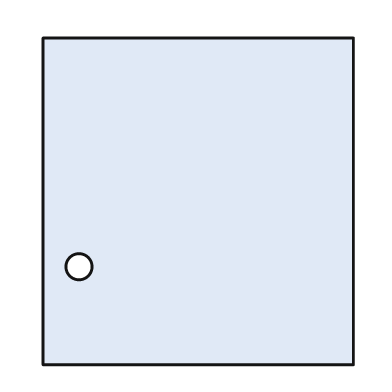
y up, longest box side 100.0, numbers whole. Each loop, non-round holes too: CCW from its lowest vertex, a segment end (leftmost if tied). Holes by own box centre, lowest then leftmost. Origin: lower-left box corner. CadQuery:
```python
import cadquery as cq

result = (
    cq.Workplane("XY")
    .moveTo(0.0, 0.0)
    .lineTo(95.0, 0.0)
    .lineTo(95.0, 100.0)
    .lineTo(0.0, 100.0)
    .close()
    .moveTo(11.0, 30.0)
    .circle(4.0)
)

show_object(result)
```